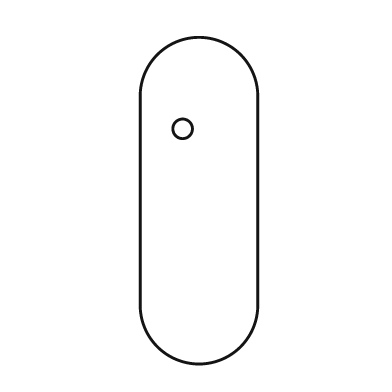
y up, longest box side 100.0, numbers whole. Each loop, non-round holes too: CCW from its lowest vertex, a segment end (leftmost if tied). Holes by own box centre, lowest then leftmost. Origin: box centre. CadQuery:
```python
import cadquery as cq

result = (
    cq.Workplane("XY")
    .moveTo(-18.0, -32.0)
    .threePointArc((0.0, -50.0), (18.0, -32.0))
    .lineTo(18.0, 32.0)
    .threePointArc((0.0, 50.0), (-18.0, 32.0))
    .close()
    .moveTo(-5.0, 22.0)
    .circle(3.0)
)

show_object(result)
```